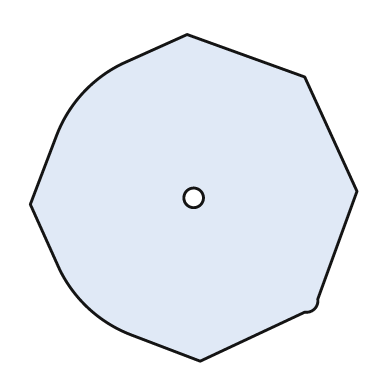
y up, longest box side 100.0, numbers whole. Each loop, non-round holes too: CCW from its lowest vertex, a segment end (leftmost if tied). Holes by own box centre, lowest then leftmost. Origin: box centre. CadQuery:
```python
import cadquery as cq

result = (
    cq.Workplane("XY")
    .moveTo(2.0, -50.0)
    .lineTo(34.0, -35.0)
    .threePointArc((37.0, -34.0), (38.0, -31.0))
    .lineTo(50.0, 2.0)
    .lineTo(34.0, 37.0)
    .lineTo(-2.0, 50.0)
    .lineTo(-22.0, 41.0)
    .threePointArc((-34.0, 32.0), (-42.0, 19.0))
    .lineTo(-50.0, -2.0)
    .lineTo(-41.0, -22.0)
    .threePointArc((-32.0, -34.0), (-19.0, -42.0))
    .close()
    .moveTo(0.0, 0.0)
    .circle(3.0)
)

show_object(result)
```